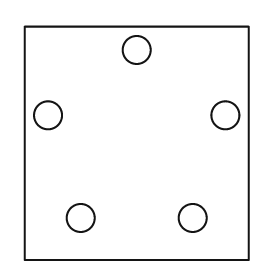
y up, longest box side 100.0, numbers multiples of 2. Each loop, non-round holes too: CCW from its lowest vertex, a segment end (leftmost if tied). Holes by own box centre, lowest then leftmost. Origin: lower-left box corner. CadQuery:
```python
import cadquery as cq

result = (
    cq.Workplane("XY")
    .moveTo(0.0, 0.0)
    .lineTo(96.0, 0.0)
    .lineTo(96.0, 100.0)
    .lineTo(0.0, 100.0)
    .close()
    .moveTo(24.0, 18.0)
    .circle(6.0)
    .moveTo(72.0, 18.0)
    .circle(6.0)
    .moveTo(10.0, 62.0)
    .circle(6.0)
    .moveTo(86.0, 62.0)
    .circle(6.0)
    .moveTo(48.0, 90.0)
    .circle(6.0)
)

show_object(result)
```